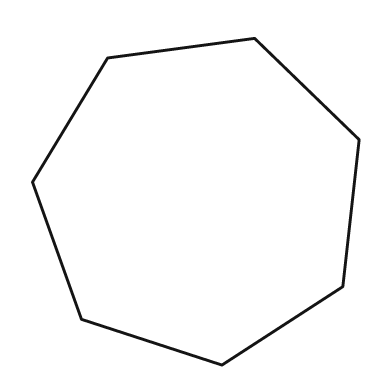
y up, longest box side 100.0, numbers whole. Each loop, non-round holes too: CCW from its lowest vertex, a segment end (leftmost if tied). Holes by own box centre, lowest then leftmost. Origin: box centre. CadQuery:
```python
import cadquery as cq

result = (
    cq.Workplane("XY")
    .moveTo(8.0, -50.0)
    .lineTo(45.0, -26.0)
    .lineTo(50.0, 19.0)
    .lineTo(18.0, 50.0)
    .lineTo(-27.0, 44.0)
    .lineTo(-50.0, 6.0)
    .lineTo(-35.0, -36.0)
    .close()
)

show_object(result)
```